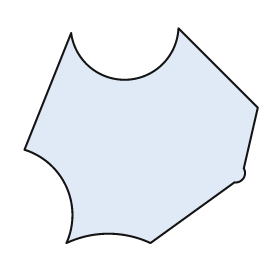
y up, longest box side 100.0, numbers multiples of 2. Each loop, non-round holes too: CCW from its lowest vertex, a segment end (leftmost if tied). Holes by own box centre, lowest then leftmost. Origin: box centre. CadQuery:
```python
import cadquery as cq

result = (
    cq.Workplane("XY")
    .moveTo(-32.0, -46.0)
    .threePointArc((-14.0, -42.0), (4.0, -46.0))
    .lineTo(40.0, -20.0)
    .threePointArc((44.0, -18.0), (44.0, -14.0))
    .lineTo(50.0, 12.0)
    .lineTo(16.0, 46.0)
    .threePointArc((-6.0, 24.0), (-30.0, 44.0))
    .lineTo(-50.0, -6.0)
    .threePointArc((-32.0, -22.0), (-32.0, -46.0))
    .close()
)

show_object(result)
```